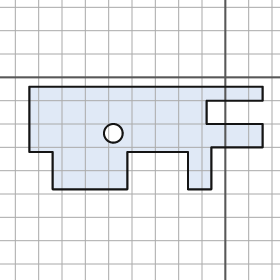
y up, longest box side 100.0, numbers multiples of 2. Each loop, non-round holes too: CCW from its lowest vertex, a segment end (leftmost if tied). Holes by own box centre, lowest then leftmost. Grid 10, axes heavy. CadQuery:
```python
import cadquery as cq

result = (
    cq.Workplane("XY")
    .moveTo(-74.0, -48.0)
    .lineTo(-42.0, -48.0)
    .lineTo(-42.0, -32.0)
    .lineTo(-16.0, -32.0)
    .lineTo(-16.0, -48.0)
    .lineTo(-6.0, -48.0)
    .lineTo(-6.0, -30.0)
    .lineTo(16.0, -30.0)
    .lineTo(16.0, -20.0)
    .lineTo(-8.0, -20.0)
    .lineTo(-8.0, -10.0)
    .lineTo(16.0, -10.0)
    .lineTo(16.0, -4.0)
    .lineTo(-84.0, -4.0)
    .lineTo(-84.0, -32.0)
    .lineTo(-74.0, -32.0)
    .close()
    .moveTo(-48.0, -24.0)
    .circle(4.0)
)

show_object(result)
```